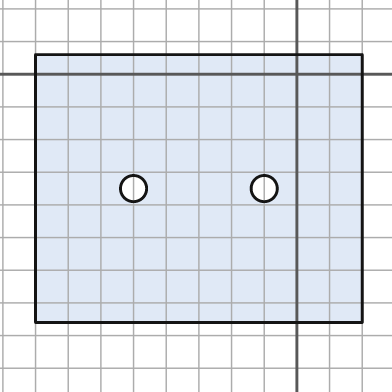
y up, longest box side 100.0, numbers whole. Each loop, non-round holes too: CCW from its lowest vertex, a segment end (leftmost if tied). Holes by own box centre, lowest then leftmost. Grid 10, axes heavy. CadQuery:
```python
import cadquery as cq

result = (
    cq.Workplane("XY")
    .moveTo(-80.0, -76.0)
    .lineTo(20.0, -76.0)
    .lineTo(20.0, 6.0)
    .lineTo(-80.0, 6.0)
    .close()
    .moveTo(-50.0, -35.0)
    .circle(4.0)
    .moveTo(-10.0, -35.0)
    .circle(4.0)
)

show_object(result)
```